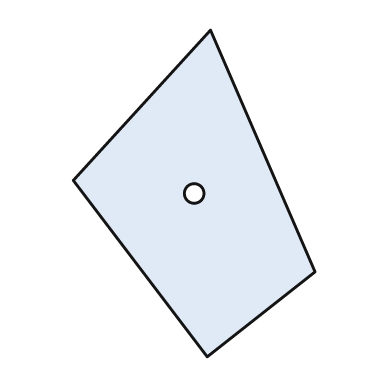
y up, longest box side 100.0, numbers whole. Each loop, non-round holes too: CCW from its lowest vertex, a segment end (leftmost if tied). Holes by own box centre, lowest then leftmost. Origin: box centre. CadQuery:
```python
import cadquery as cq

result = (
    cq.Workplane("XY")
    .moveTo(4.0, -50.0)
    .lineTo(37.0, -24.0)
    .lineTo(5.0, 50.0)
    .lineTo(-37.0, 4.0)
    .close()
    .moveTo(0.0, 0.0)
    .circle(3.0)
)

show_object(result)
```